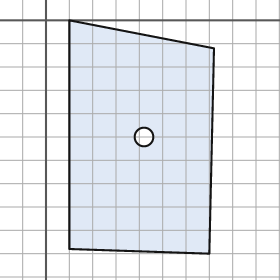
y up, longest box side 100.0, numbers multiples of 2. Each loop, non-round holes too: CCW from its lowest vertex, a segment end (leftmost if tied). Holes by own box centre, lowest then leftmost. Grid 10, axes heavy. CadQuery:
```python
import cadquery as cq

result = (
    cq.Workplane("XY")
    .moveTo(70.0, -100.0)
    .lineTo(72.0, -12.0)
    .lineTo(10.0, 0.0)
    .lineTo(10.0, -98.0)
    .close()
    .moveTo(42.0, -50.0)
    .circle(4.0)
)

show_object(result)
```